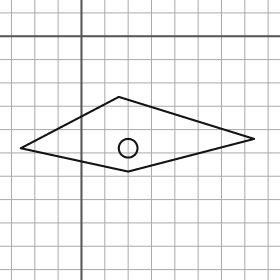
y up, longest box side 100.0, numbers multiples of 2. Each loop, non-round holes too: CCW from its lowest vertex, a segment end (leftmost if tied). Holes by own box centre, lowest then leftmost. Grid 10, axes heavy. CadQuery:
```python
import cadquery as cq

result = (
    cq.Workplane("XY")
    .moveTo(20.0, -58.0)
    .lineTo(74.0, -44.0)
    .lineTo(16.0, -26.0)
    .lineTo(-26.0, -48.0)
    .close()
    .moveTo(20.0, -48.0)
    .circle(4.0)
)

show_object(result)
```